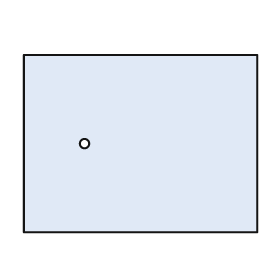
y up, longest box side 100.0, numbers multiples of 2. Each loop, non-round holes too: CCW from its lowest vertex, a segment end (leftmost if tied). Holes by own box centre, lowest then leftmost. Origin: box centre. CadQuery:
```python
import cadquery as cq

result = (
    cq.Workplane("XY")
    .moveTo(-50.0, -38.0)
    .lineTo(50.0, -38.0)
    .lineTo(50.0, 38.0)
    .lineTo(-50.0, 38.0)
    .close()
    .moveTo(-24.0, 0.0)
    .circle(2.0)
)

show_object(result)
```